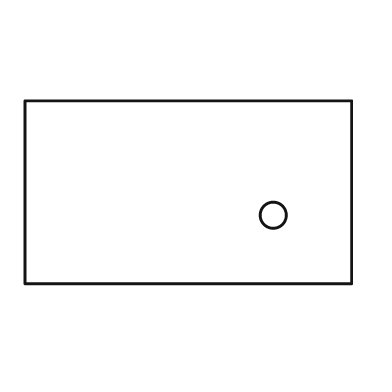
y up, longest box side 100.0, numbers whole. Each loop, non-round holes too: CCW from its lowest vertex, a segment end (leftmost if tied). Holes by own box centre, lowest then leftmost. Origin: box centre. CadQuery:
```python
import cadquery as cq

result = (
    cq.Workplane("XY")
    .moveTo(-50.0, -28.0)
    .lineTo(50.0, -28.0)
    .lineTo(50.0, 28.0)
    .lineTo(-50.0, 28.0)
    .close()
    .moveTo(26.0, -7.0)
    .circle(4.0)
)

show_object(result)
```